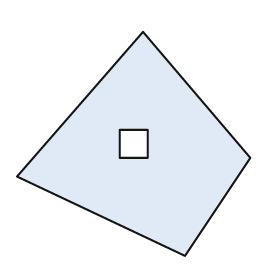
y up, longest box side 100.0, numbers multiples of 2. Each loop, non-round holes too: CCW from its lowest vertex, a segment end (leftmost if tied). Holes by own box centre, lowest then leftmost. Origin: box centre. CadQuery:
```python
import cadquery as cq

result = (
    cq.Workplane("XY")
    .moveTo(22.0, -48.0)
    .lineTo(50.0, -6.0)
    .lineTo(4.0, 48.0)
    .lineTo(-50.0, -14.0)
    .close()
    .moveTo(-6.0, -6.0)
    .lineTo(6.0, -6.0)
    .lineTo(6.0, 6.0)
    .lineTo(-6.0, 6.0)
    .close()
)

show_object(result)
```